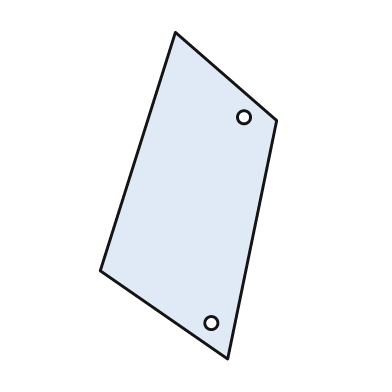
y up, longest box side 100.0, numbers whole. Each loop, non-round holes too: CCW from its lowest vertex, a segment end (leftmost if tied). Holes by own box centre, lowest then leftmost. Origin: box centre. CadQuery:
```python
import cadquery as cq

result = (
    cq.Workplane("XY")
    .moveTo(12.0, -50.0)
    .lineTo(27.0, 23.0)
    .lineTo(-4.0, 50.0)
    .lineTo(-27.0, -23.0)
    .close()
    .moveTo(7.0, -39.0)
    .circle(2.0)
    .moveTo(17.0, 24.0)
    .circle(2.0)
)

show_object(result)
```